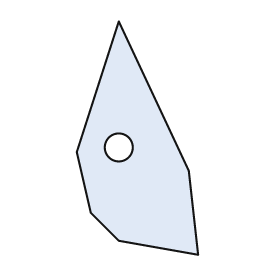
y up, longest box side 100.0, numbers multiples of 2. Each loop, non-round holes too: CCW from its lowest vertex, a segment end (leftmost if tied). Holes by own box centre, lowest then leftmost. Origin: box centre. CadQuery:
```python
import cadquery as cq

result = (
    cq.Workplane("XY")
    .moveTo(26.0, -50.0)
    .lineTo(22.0, -14.0)
    .lineTo(-8.0, 50.0)
    .lineTo(-26.0, -6.0)
    .lineTo(-20.0, -32.0)
    .lineTo(-8.0, -44.0)
    .close()
    .moveTo(-8.0, -4.0)
    .circle(6.0)
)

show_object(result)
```